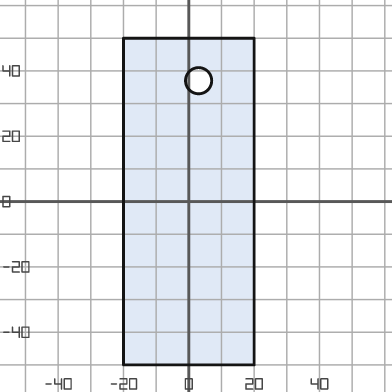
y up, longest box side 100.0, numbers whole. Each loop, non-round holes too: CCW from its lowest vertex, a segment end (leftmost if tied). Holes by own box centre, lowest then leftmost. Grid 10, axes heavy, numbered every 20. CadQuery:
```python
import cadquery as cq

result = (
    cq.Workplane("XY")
    .moveTo(-20.0, -50.0)
    .lineTo(20.0, -50.0)
    .lineTo(20.0, 50.0)
    .lineTo(-20.0, 50.0)
    .close()
    .moveTo(3.0, 37.0)
    .circle(4.0)
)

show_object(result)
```